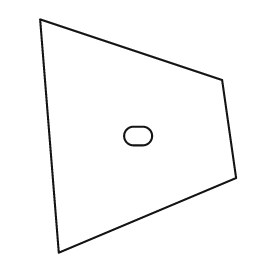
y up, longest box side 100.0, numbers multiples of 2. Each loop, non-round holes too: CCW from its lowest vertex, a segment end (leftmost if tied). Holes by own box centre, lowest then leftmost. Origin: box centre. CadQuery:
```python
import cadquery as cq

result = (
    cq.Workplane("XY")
    .moveTo(-34.0, -50.0)
    .lineTo(42.0, -18.0)
    .lineTo(36.0, 24.0)
    .lineTo(-42.0, 50.0)
    .close()
    .moveTo(-2.0, -4.0)
    .lineTo(2.0, -4.0)
    .threePointArc((6.0, 0.0), (2.0, 4.0))
    .lineTo(-2.0, 4.0)
    .threePointArc((-6.0, 0.0), (-2.0, -4.0))
    .close()
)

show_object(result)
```